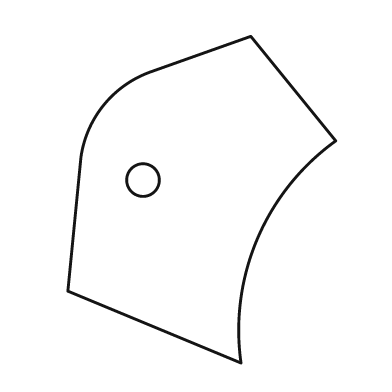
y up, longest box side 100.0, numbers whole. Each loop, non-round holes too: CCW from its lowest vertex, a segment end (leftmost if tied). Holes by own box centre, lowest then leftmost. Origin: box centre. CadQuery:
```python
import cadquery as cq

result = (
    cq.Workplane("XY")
    .moveTo(12.0, -50.0)
    .threePointArc((17.0, -12.0), (41.0, 18.0))
    .lineTo(15.0, 50.0)
    .lineTo(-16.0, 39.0)
    .threePointArc((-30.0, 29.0), (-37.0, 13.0))
    .lineTo(-41.0, -28.0)
    .close()
    .moveTo(-18.0, 6.0)
    .circle(5.0)
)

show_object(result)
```